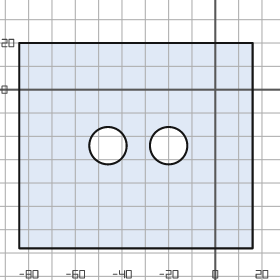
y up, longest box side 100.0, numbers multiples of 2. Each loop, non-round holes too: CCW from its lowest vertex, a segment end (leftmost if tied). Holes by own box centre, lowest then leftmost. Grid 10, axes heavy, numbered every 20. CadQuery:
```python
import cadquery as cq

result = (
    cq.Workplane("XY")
    .moveTo(-84.0, -68.0)
    .lineTo(16.0, -68.0)
    .lineTo(16.0, 20.0)
    .lineTo(-84.0, 20.0)
    .close()
    .moveTo(-46.0, -24.0)
    .circle(8.0)
    .moveTo(-20.0, -24.0)
    .circle(8.0)
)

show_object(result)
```